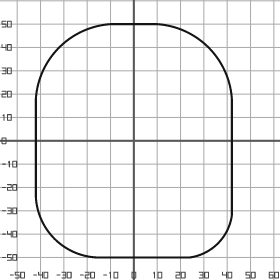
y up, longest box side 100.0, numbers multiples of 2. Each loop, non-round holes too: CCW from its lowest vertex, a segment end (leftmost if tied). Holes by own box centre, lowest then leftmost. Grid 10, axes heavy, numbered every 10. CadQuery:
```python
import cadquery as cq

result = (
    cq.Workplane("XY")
    .moveTo(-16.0, -50.0)
    .lineTo(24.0, -50.0)
    .threePointArc((36.0, -44.0), (42.0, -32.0))
    .lineTo(42.0, 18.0)
    .threePointArc((32.0, 40.0), (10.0, 50.0))
    .lineTo(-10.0, 50.0)
    .threePointArc((-32.0, 40.0), (-42.0, 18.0))
    .lineTo(-42.0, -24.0)
    .threePointArc((-34.0, -42.0), (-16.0, -50.0))
    .close()
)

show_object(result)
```